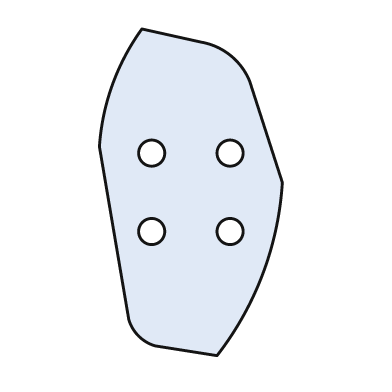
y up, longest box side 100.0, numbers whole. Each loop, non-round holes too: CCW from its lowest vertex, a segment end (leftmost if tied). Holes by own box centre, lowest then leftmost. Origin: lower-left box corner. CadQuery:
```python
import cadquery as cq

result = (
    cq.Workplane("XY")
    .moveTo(36.0, 0.0)
    .threePointArc((50.0, 25.0), (56.0, 53.0))
    .lineTo(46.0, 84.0)
    .threePointArc((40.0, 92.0), (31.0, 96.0))
    .lineTo(13.0, 100.0)
    .threePointArc((4.0, 83.0), (0.0, 64.0))
    .lineTo(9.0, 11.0)
    .threePointArc((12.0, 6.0), (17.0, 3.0))
    .close()
    .moveTo(16.0, 38.0)
    .circle(4.0)
    .moveTo(40.0, 38.0)
    .circle(4.0)
    .moveTo(16.0, 62.0)
    .circle(4.0)
    .moveTo(40.0, 62.0)
    .circle(4.0)
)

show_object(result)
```